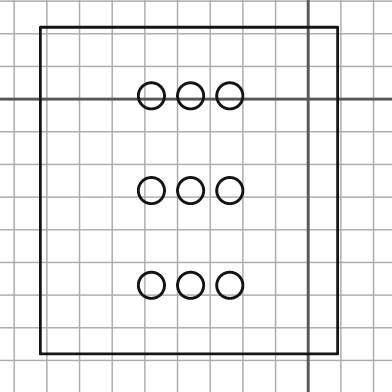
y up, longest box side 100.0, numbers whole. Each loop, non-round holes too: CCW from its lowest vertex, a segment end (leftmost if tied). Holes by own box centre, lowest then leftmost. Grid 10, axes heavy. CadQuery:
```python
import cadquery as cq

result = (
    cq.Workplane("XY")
    .moveTo(-82.0, -78.0)
    .lineTo(9.0, -78.0)
    .lineTo(9.0, 22.0)
    .lineTo(-82.0, 22.0)
    .close()
    .moveTo(-48.0, -57.0)
    .circle(4.0)
    .moveTo(-36.0, -57.0)
    .circle(4.0)
    .moveTo(-24.0, -57.0)
    .circle(4.0)
    .moveTo(-48.0, -28.0)
    .circle(4.0)
    .moveTo(-36.0, -28.0)
    .circle(4.0)
    .moveTo(-24.0, -28.0)
    .circle(4.0)
    .moveTo(-48.0, 1.0)
    .circle(4.0)
    .moveTo(-36.0, 1.0)
    .circle(4.0)
    .moveTo(-24.0, 1.0)
    .circle(4.0)
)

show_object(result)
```